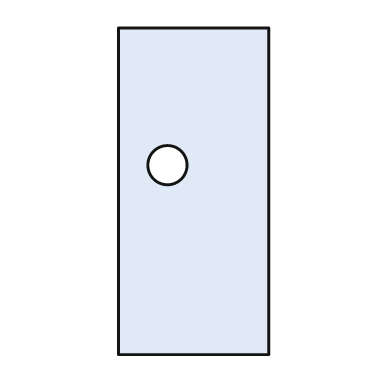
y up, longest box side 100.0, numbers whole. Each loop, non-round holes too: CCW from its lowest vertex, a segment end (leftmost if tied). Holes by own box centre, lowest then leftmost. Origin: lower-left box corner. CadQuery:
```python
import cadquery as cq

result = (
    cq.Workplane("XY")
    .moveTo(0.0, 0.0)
    .lineTo(46.0, 0.0)
    .lineTo(46.0, 100.0)
    .lineTo(0.0, 100.0)
    .close()
    .moveTo(15.0, 58.0)
    .circle(6.0)
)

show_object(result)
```